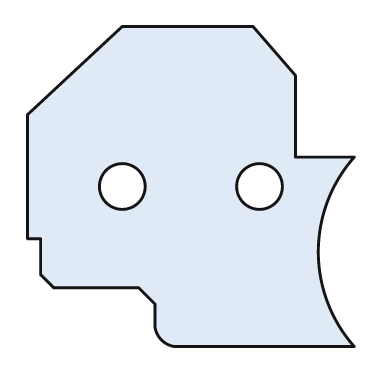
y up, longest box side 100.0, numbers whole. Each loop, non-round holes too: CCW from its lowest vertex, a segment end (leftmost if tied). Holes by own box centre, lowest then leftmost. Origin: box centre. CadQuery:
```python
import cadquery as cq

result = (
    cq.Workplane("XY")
    .moveTo(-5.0, -49.0)
    .lineTo(50.0, -49.0)
    .threePointArc((39.0, -20.0), (50.0, 9.0))
    .lineTo(32.0, 9.0)
    .lineTo(32.0, 34.0)
    .lineTo(19.0, 49.0)
    .lineTo(-21.0, 49.0)
    .lineTo(-50.0, 22.0)
    .lineTo(-50.0, -16.0)
    .lineTo(-46.0, -16.0)
    .lineTo(-46.0, -27.0)
    .lineTo(-42.0, -31.0)
    .lineTo(-16.0, -31.0)
    .lineTo(-11.0, -36.0)
    .lineTo(-11.0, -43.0)
    .threePointArc((-9.0, -47.0), (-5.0, -49.0))
    .close()
    .moveTo(-21.0, 0.0)
    .circle(7.0)
    .moveTo(21.0, 0.0)
    .circle(7.0)
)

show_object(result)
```